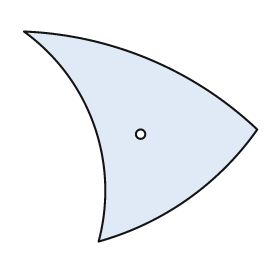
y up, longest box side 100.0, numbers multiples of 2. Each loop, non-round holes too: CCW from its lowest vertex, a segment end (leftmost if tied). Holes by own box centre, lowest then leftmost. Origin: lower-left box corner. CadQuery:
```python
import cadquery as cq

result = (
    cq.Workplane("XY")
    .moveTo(32.0, 0.0)
    .threePointArc((70.0, 18.0), (100.0, 48.0))
    .threePointArc((54.0, 78.0), (0.0, 90.0))
    .threePointArc((30.0, 50.0), (32.0, 0.0))
    .close()
    .moveTo(50.0, 46.0)
    .circle(2.0)
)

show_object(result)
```